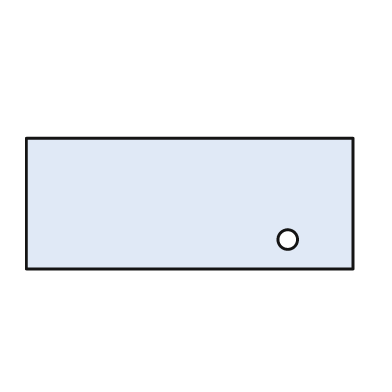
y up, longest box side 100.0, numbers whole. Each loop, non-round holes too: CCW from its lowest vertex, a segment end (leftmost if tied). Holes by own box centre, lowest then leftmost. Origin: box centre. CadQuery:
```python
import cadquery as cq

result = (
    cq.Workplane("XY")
    .moveTo(-50.0, -20.0)
    .lineTo(50.0, -20.0)
    .lineTo(50.0, 20.0)
    .lineTo(-50.0, 20.0)
    .close()
    .moveTo(30.0, -11.0)
    .circle(3.0)
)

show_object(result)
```